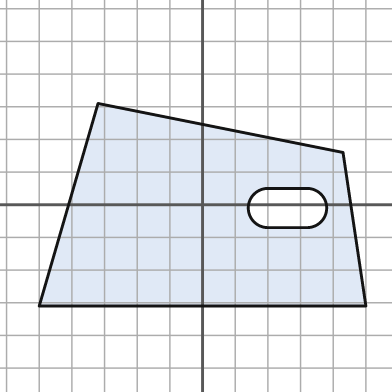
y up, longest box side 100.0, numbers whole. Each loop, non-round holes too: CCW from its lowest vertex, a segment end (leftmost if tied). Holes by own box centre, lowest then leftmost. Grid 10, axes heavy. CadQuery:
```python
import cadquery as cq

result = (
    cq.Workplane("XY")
    .moveTo(-50.0, -31.0)
    .lineTo(50.0, -31.0)
    .lineTo(43.0, 16.0)
    .lineTo(-32.0, 31.0)
    .close()
    .moveTo(20.0, -7.0)
    .lineTo(32.0, -7.0)
    .threePointArc((38.0, -1.0), (32.0, 5.0))
    .lineTo(20.0, 5.0)
    .threePointArc((14.0, -1.0), (20.0, -7.0))
    .close()
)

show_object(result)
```